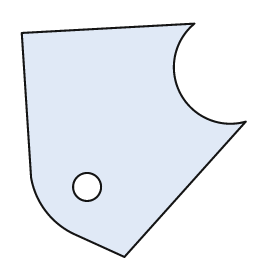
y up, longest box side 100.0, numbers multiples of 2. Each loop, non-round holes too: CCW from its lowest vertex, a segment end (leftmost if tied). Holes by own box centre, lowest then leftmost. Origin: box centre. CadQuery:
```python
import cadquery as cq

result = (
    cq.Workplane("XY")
    .moveTo(-4.0, -50.0)
    .lineTo(48.0, 8.0)
    .threePointArc((20.0, 20.0), (26.0, 50.0))
    .lineTo(-48.0, 46.0)
    .lineTo(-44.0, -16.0)
    .threePointArc((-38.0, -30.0), (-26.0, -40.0))
    .close()
    .moveTo(-20.0, -20.0)
    .circle(6.0)
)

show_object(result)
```